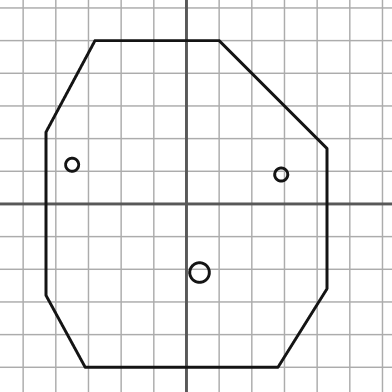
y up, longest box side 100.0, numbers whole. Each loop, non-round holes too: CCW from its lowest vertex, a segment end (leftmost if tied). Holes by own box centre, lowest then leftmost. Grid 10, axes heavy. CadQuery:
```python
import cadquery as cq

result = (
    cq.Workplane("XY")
    .moveTo(-31.0, -50.0)
    .lineTo(28.0, -50.0)
    .lineTo(43.0, -26.0)
    .lineTo(43.0, 17.0)
    .lineTo(10.0, 50.0)
    .lineTo(-28.0, 50.0)
    .lineTo(-43.0, 22.0)
    .lineTo(-43.0, -28.0)
    .close()
    .moveTo(4.0, -21.0)
    .circle(3.0)
    .moveTo(29.0, 9.0)
    .circle(2.0)
    .moveTo(-35.0, 12.0)
    .circle(2.0)
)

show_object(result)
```